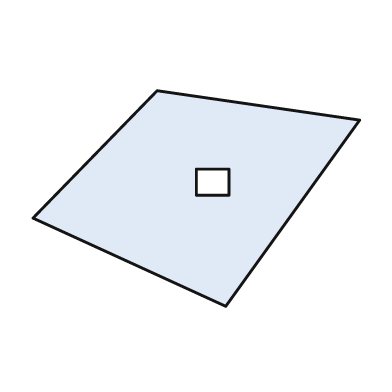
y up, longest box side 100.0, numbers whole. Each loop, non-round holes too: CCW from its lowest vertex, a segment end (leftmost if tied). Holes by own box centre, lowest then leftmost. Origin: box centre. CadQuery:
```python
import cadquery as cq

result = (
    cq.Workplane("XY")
    .moveTo(9.0, -33.0)
    .lineTo(50.0, 24.0)
    .lineTo(-12.0, 33.0)
    .lineTo(-50.0, -6.0)
    .close()
    .moveTo(0.0, 1.0)
    .lineTo(10.0, 1.0)
    .lineTo(10.0, 9.0)
    .lineTo(0.0, 9.0)
    .close()
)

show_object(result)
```